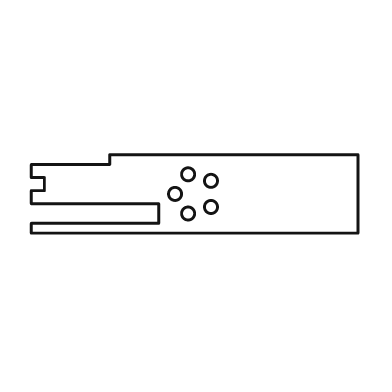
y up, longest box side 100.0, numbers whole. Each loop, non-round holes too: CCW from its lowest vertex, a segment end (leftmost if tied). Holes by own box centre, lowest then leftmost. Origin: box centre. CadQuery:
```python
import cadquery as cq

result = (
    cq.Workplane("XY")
    .moveTo(-50.0, -12.0)
    .lineTo(50.0, -12.0)
    .lineTo(50.0, 12.0)
    .lineTo(-26.0, 12.0)
    .lineTo(-26.0, 9.0)
    .lineTo(-50.0, 9.0)
    .lineTo(-50.0, 5.0)
    .lineTo(-46.0, 5.0)
    .lineTo(-46.0, 1.0)
    .lineTo(-50.0, 1.0)
    .lineTo(-50.0, -3.0)
    .lineTo(-11.0, -3.0)
    .lineTo(-11.0, -9.0)
    .lineTo(-50.0, -9.0)
    .close()
    .moveTo(-2.0, -6.0)
    .circle(2.0)
    .moveTo(5.0, -4.0)
    .circle(2.0)
    .moveTo(-6.0, 0.0)
    .circle(2.0)
    .moveTo(5.0, 4.0)
    .circle(2.0)
    .moveTo(-2.0, 6.0)
    .circle(2.0)
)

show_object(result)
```